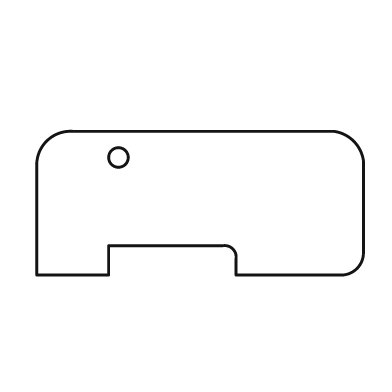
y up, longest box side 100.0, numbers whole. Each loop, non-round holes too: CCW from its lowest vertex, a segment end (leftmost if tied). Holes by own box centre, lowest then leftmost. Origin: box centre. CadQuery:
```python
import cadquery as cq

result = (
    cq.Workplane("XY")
    .moveTo(-50.0, -22.0)
    .lineTo(-28.0, -22.0)
    .lineTo(-28.0, -13.0)
    .lineTo(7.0, -13.0)
    .threePointArc((10.0, -14.0), (11.0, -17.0))
    .lineTo(11.0, -22.0)
    .lineTo(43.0, -22.0)
    .threePointArc((48.0, -20.0), (50.0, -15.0))
    .lineTo(50.0, 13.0)
    .threePointArc((47.0, 19.0), (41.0, 22.0))
    .lineTo(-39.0, 22.0)
    .threePointArc((-47.0, 19.0), (-50.0, 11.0))
    .close()
    .moveTo(-25.0, 14.0)
    .circle(3.0)
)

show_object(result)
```